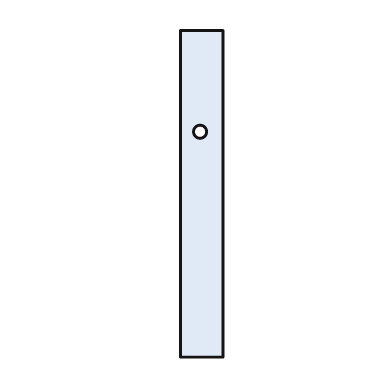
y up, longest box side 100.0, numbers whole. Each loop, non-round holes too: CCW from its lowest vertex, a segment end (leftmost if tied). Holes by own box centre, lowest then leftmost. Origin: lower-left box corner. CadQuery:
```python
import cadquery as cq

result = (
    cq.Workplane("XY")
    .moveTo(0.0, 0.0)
    .lineTo(13.0, 0.0)
    .lineTo(13.0, 100.0)
    .lineTo(0.0, 100.0)
    .close()
    .moveTo(6.0, 69.0)
    .circle(2.0)
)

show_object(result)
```